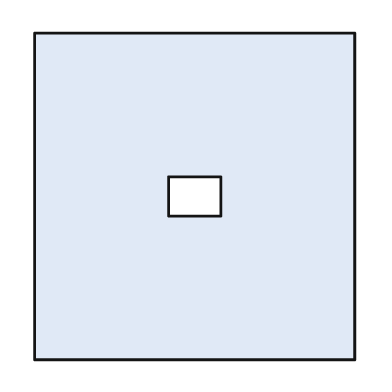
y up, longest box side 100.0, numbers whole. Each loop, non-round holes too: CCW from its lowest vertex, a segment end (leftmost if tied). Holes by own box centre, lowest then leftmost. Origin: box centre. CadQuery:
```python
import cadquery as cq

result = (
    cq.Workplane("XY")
    .moveTo(-49.0, -50.0)
    .lineTo(49.0, -50.0)
    .lineTo(49.0, 50.0)
    .lineTo(-49.0, 50.0)
    .close()
    .moveTo(-8.0, -6.0)
    .lineTo(8.0, -6.0)
    .lineTo(8.0, 6.0)
    .lineTo(-8.0, 6.0)
    .close()
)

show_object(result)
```